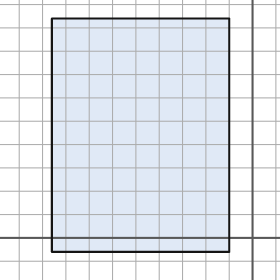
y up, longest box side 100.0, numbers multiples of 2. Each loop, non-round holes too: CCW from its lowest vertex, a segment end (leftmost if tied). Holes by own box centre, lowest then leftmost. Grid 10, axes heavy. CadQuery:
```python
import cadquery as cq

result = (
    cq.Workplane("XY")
    .moveTo(-86.0, -6.0)
    .lineTo(-10.0, -6.0)
    .lineTo(-10.0, 94.0)
    .lineTo(-86.0, 94.0)
    .close()
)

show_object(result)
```